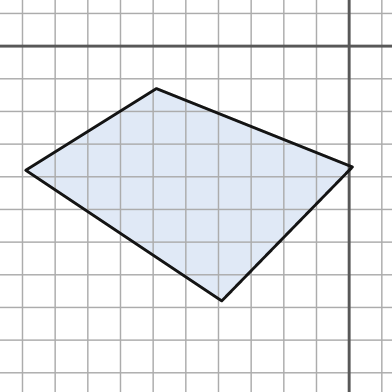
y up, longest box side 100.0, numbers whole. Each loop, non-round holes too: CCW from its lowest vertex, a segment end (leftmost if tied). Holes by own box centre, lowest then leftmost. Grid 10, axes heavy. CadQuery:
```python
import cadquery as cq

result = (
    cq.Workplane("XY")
    .moveTo(-39.0, -78.0)
    .lineTo(1.0, -37.0)
    .lineTo(-59.0, -13.0)
    .lineTo(-99.0, -38.0)
    .close()
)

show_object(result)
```